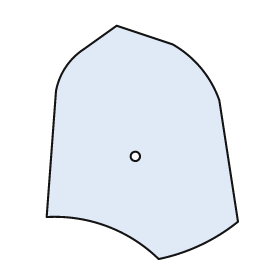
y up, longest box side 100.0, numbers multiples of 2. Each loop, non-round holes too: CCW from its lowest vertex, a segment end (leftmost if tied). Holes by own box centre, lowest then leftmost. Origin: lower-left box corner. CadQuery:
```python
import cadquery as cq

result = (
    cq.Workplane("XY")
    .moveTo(48.0, 0.0)
    .threePointArc((66.0, 6.0), (82.0, 16.0))
    .lineTo(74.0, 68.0)
    .threePointArc((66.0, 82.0), (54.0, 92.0))
    .lineTo(30.0, 100.0)
    .lineTo(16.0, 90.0)
    .threePointArc((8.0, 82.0), (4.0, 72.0))
    .lineTo(0.0, 18.0)
    .threePointArc((26.0, 14.0), (48.0, 0.0))
    .close()
    .moveTo(38.0, 44.0)
    .circle(2.0)
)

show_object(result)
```